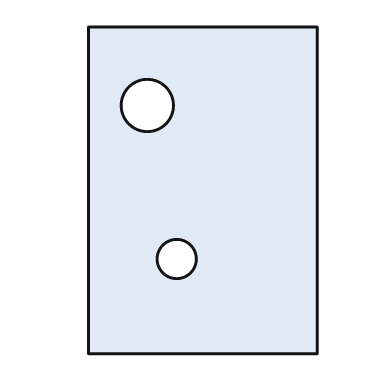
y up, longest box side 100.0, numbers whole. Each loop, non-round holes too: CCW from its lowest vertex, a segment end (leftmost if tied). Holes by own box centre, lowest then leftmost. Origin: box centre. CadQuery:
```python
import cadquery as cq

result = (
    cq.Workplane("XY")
    .moveTo(-35.0, -50.0)
    .lineTo(35.0, -50.0)
    .lineTo(35.0, 50.0)
    .lineTo(-35.0, 50.0)
    .close()
    .moveTo(-8.0, -21.0)
    .circle(6.0)
    .moveTo(-17.0, 26.0)
    .circle(8.0)
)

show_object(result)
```